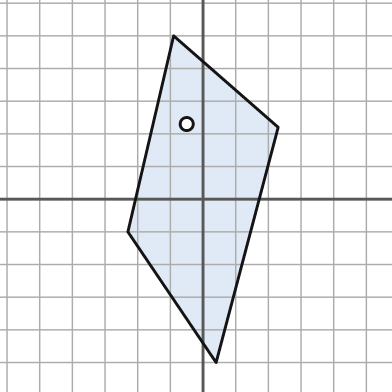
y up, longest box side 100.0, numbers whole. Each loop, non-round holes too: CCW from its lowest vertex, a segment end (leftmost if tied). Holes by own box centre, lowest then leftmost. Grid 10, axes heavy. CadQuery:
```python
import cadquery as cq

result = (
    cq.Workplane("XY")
    .moveTo(4.0, -50.0)
    .lineTo(23.0, 22.0)
    .lineTo(-9.0, 50.0)
    .lineTo(-23.0, -10.0)
    .close()
    .moveTo(-5.0, 23.0)
    .circle(2.0)
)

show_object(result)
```